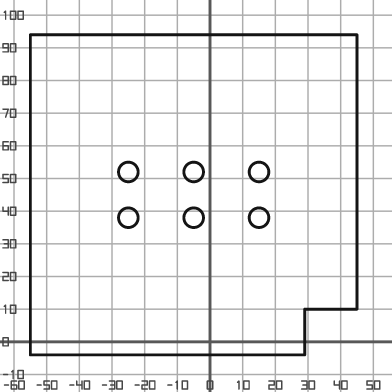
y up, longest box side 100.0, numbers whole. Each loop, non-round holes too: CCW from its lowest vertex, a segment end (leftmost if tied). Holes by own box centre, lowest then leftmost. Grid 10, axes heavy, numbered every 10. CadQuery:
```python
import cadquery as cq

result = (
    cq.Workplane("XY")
    .moveTo(-55.0, -4.0)
    .lineTo(29.0, -4.0)
    .lineTo(29.0, 10.0)
    .lineTo(45.0, 10.0)
    .lineTo(45.0, 94.0)
    .lineTo(-55.0, 94.0)
    .close()
    .moveTo(-25.0, 38.0)
    .circle(3.0)
    .moveTo(-5.0, 38.0)
    .circle(3.0)
    .moveTo(15.0, 38.0)
    .circle(3.0)
    .moveTo(-25.0, 52.0)
    .circle(3.0)
    .moveTo(-5.0, 52.0)
    .circle(3.0)
    .moveTo(15.0, 52.0)
    .circle(3.0)
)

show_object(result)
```